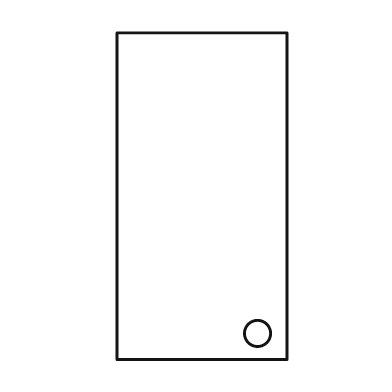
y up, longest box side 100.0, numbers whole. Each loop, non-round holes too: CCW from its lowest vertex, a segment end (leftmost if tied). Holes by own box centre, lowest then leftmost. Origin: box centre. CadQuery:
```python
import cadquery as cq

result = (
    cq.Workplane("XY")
    .moveTo(-26.0, -50.0)
    .lineTo(26.0, -50.0)
    .lineTo(26.0, 50.0)
    .lineTo(-26.0, 50.0)
    .close()
    .moveTo(17.0, -42.0)
    .circle(4.0)
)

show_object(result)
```